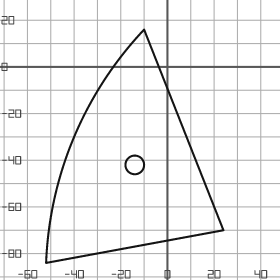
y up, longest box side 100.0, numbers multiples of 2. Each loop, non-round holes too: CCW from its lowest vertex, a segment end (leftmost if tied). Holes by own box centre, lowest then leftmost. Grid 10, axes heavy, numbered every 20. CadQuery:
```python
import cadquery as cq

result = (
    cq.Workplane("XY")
    .moveTo(-52.0, -84.0)
    .lineTo(24.0, -70.0)
    .lineTo(-10.0, 16.0)
    .threePointArc((-40.0, -30.0), (-52.0, -84.0))
    .close()
    .moveTo(-14.0, -42.0)
    .circle(4.0)
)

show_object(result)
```